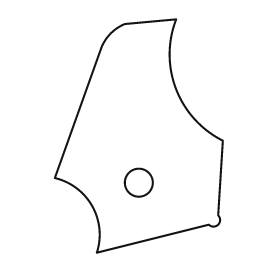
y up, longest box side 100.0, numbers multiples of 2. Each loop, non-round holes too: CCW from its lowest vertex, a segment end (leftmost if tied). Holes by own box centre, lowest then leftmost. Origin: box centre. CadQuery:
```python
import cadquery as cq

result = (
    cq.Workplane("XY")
    .moveTo(-18.0, -50.0)
    .lineTo(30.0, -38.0)
    .threePointArc((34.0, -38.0), (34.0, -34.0))
    .lineTo(36.0, -2.0)
    .threePointArc((16.0, 20.0), (16.0, 50.0))
    .lineTo(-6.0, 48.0)
    .threePointArc((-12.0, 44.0), (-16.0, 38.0))
    .lineTo(-36.0, -18.0)
    .threePointArc((-20.0, -30.0), (-18.0, -50.0))
    .close()
    .moveTo(0.0, -20.0)
    .circle(6.0)
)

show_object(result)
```